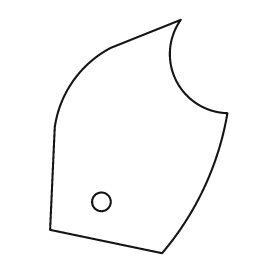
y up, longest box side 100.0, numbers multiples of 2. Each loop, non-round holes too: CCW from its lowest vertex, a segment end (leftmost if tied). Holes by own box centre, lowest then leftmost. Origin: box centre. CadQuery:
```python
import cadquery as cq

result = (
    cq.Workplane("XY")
    .moveTo(10.0, -50.0)
    .threePointArc((28.0, -22.0), (38.0, 10.0))
    .threePointArc((16.0, 24.0), (18.0, 50.0))
    .lineTo(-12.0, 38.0)
    .threePointArc((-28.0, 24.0), (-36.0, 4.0))
    .lineTo(-38.0, -40.0)
    .close()
    .moveTo(-16.0, -28.0)
    .circle(4.0)
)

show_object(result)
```